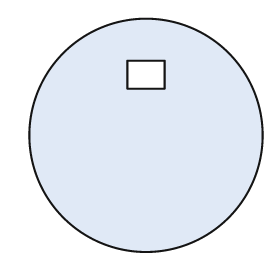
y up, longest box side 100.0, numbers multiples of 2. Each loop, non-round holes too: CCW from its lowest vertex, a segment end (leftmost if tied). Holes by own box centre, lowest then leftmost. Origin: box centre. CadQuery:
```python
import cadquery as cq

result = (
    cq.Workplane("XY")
    .moveTo(0.0, 0.0)
    .circle(50.0)
    .moveTo(-8.0, 20.0)
    .lineTo(8.0, 20.0)
    .lineTo(8.0, 32.0)
    .lineTo(-8.0, 32.0)
    .close()
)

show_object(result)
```